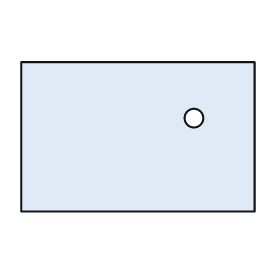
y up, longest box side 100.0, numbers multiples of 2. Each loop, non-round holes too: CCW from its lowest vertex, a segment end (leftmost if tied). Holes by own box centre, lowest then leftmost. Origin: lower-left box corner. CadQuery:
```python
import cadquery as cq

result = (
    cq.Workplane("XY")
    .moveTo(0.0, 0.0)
    .lineTo(100.0, 0.0)
    .lineTo(100.0, 64.0)
    .lineTo(0.0, 64.0)
    .close()
    .moveTo(74.0, 40.0)
    .circle(4.0)
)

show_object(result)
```